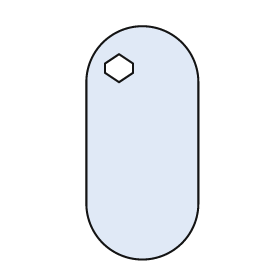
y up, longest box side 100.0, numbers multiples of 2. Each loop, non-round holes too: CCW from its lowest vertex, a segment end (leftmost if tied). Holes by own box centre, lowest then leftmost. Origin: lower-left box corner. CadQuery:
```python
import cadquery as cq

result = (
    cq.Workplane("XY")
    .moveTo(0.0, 24.0)
    .threePointArc((24.0, 0.0), (48.0, 24.0))
    .lineTo(48.0, 76.0)
    .threePointArc((24.0, 100.0), (0.0, 76.0))
    .close()
    .moveTo(14.0, 76.0)
    .lineTo(20.0, 80.0)
    .lineTo(20.0, 84.0)
    .lineTo(14.0, 88.0)
    .lineTo(8.0, 84.0)
    .lineTo(8.0, 80.0)
    .close()
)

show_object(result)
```